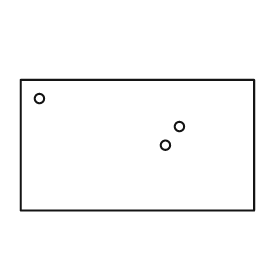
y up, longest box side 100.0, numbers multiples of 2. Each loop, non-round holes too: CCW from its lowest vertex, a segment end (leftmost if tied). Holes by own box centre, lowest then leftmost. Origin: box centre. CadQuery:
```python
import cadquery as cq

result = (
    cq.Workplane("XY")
    .moveTo(-50.0, -28.0)
    .lineTo(50.0, -28.0)
    .lineTo(50.0, 28.0)
    .lineTo(-50.0, 28.0)
    .close()
    .moveTo(12.0, 0.0)
    .circle(2.0)
    .moveTo(18.0, 8.0)
    .circle(2.0)
    .moveTo(-42.0, 20.0)
    .circle(2.0)
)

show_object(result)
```